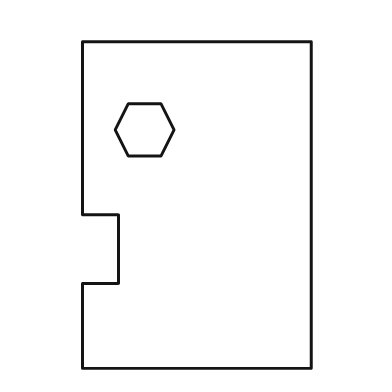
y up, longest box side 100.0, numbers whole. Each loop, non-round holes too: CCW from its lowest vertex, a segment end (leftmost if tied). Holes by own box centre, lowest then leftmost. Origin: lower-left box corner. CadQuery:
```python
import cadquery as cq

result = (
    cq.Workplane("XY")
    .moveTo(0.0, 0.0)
    .lineTo(70.0, 0.0)
    .lineTo(70.0, 100.0)
    .lineTo(0.0, 100.0)
    .lineTo(0.0, 47.0)
    .lineTo(11.0, 47.0)
    .lineTo(11.0, 26.0)
    .lineTo(0.0, 26.0)
    .close()
    .moveTo(14.0, 65.0)
    .lineTo(24.0, 65.0)
    .lineTo(28.0, 73.0)
    .lineTo(24.0, 81.0)
    .lineTo(14.0, 81.0)
    .lineTo(10.0, 73.0)
    .close()
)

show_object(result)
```